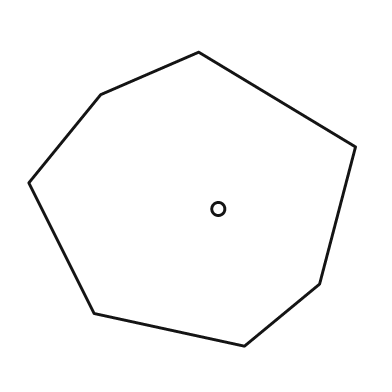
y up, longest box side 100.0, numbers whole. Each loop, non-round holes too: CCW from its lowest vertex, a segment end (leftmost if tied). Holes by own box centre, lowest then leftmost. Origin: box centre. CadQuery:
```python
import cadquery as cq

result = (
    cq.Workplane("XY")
    .moveTo(16.0, -45.0)
    .lineTo(39.0, -26.0)
    .lineTo(50.0, 16.0)
    .lineTo(2.0, 45.0)
    .lineTo(-28.0, 32.0)
    .lineTo(-50.0, 5.0)
    .lineTo(-30.0, -35.0)
    .close()
    .moveTo(8.0, -3.0)
    .circle(2.0)
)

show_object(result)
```